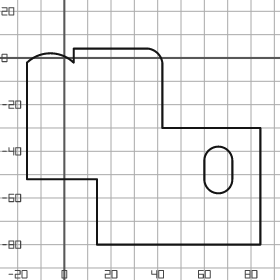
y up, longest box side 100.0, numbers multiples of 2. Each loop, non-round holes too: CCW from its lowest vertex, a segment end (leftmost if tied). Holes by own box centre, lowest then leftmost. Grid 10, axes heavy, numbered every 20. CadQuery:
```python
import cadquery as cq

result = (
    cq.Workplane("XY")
    .moveTo(14.0, -80.0)
    .lineTo(84.0, -80.0)
    .lineTo(84.0, -30.0)
    .lineTo(42.0, -30.0)
    .lineTo(42.0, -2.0)
    .threePointArc((40.0, 2.0), (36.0, 4.0))
    .lineTo(4.0, 4.0)
    .lineTo(4.0, -2.0)
    .threePointArc((-6.0, 2.0), (-16.0, -2.0))
    .lineTo(-16.0, -52.0)
    .lineTo(14.0, -52.0)
    .close()
    .moveTo(60.0, -52.0)
    .threePointArc((66.0, -58.0), (72.0, -52.0))
    .lineTo(72.0, -44.0)
    .threePointArc((66.0, -38.0), (60.0, -44.0))
    .close()
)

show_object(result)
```